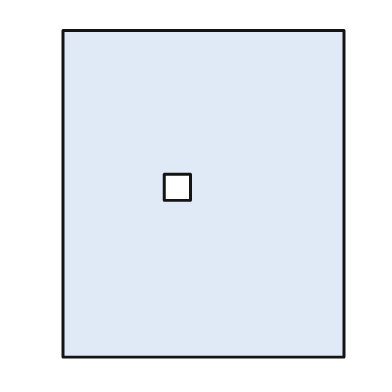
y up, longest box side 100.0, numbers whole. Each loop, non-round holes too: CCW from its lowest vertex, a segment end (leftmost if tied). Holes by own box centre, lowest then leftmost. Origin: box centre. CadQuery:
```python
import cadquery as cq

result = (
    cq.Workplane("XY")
    .moveTo(-43.0, -50.0)
    .lineTo(43.0, -50.0)
    .lineTo(43.0, 50.0)
    .lineTo(-43.0, 50.0)
    .close()
    .moveTo(-12.0, -2.0)
    .lineTo(-4.0, -2.0)
    .lineTo(-4.0, 6.0)
    .lineTo(-12.0, 6.0)
    .close()
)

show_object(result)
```